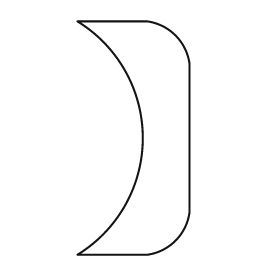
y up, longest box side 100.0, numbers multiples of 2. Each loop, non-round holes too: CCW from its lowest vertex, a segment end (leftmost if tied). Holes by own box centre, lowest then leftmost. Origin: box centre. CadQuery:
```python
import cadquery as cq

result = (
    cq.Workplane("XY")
    .moveTo(-24.0, -50.0)
    .lineTo(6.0, -50.0)
    .threePointArc((18.0, -44.0), (24.0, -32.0))
    .lineTo(24.0, 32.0)
    .threePointArc((18.0, 44.0), (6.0, 50.0))
    .lineTo(-24.0, 50.0)
    .threePointArc((4.0, 0.0), (-24.0, -50.0))
    .close()
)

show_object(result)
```